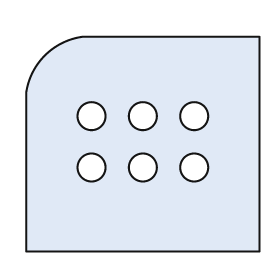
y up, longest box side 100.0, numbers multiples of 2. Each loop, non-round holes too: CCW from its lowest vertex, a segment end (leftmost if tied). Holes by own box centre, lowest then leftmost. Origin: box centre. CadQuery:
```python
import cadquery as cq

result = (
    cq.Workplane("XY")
    .moveTo(-50.0, -46.0)
    .lineTo(50.0, -46.0)
    .lineTo(50.0, 46.0)
    .lineTo(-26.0, 46.0)
    .threePointArc((-42.0, 38.0), (-50.0, 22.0))
    .close()
    .moveTo(-22.0, -10.0)
    .circle(6.0)
    .moveTo(0.0, -10.0)
    .circle(6.0)
    .moveTo(22.0, -10.0)
    .circle(6.0)
    .moveTo(-22.0, 12.0)
    .circle(6.0)
    .moveTo(0.0, 12.0)
    .circle(6.0)
    .moveTo(22.0, 12.0)
    .circle(6.0)
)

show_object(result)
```